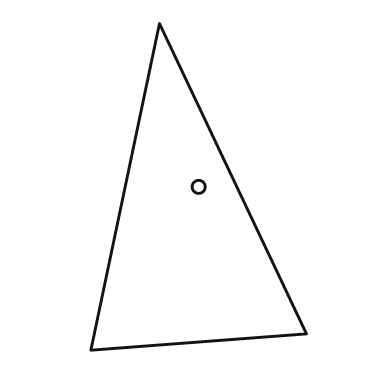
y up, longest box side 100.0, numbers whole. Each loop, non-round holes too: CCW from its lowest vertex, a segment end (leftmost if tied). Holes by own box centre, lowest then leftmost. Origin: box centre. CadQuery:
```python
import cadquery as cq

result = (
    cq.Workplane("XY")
    .moveTo(-33.0, -50.0)
    .lineTo(33.0, -45.0)
    .lineTo(-12.0, 50.0)
    .close()
    .moveTo(0.0, 0.0)
    .circle(2.0)
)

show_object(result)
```